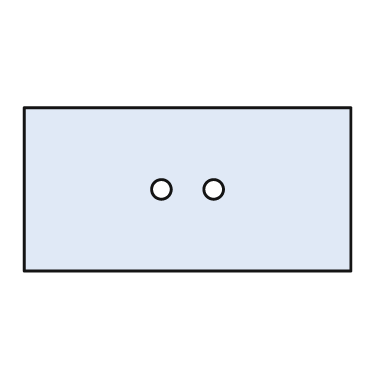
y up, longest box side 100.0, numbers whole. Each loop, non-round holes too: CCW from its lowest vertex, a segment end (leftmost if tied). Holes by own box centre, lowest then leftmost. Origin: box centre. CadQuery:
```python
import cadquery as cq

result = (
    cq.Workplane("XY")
    .moveTo(-50.0, -25.0)
    .lineTo(50.0, -25.0)
    .lineTo(50.0, 25.0)
    .lineTo(-50.0, 25.0)
    .close()
    .moveTo(-8.0, 0.0)
    .circle(3.0)
    .moveTo(8.0, 0.0)
    .circle(3.0)
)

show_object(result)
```